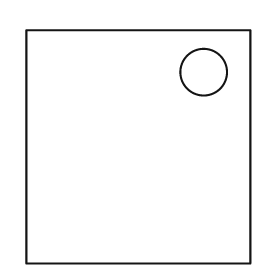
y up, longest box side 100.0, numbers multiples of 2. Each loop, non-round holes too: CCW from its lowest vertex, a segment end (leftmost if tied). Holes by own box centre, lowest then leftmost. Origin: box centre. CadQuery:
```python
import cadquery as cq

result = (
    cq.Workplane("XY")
    .moveTo(-48.0, -50.0)
    .lineTo(48.0, -50.0)
    .lineTo(48.0, 50.0)
    .lineTo(-48.0, 50.0)
    .close()
    .moveTo(28.0, 32.0)
    .circle(10.0)
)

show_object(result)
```